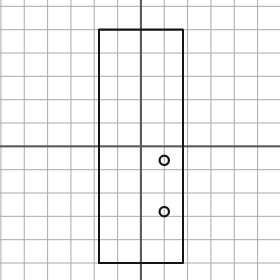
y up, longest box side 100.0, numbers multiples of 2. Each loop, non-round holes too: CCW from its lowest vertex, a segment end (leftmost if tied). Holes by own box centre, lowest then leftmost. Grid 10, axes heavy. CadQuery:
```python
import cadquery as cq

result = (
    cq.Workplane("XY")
    .moveTo(-18.0, -50.0)
    .lineTo(18.0, -50.0)
    .lineTo(18.0, 50.0)
    .lineTo(-18.0, 50.0)
    .close()
    .moveTo(10.0, -28.0)
    .circle(2.0)
    .moveTo(10.0, -6.0)
    .circle(2.0)
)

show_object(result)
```